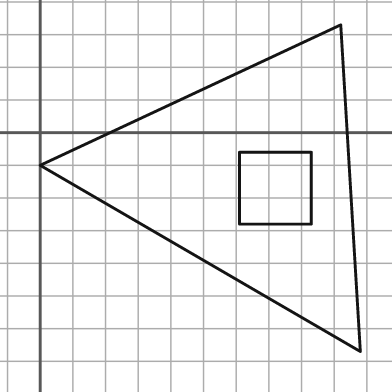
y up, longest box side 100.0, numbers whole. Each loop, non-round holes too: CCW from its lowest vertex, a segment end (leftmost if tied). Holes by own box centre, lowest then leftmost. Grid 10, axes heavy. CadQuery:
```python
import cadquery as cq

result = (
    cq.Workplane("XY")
    .moveTo(98.0, -67.0)
    .lineTo(92.0, 33.0)
    .lineTo(0.0, -10.0)
    .close()
    .moveTo(61.0, -28.0)
    .lineTo(83.0, -28.0)
    .lineTo(83.0, -6.0)
    .lineTo(61.0, -6.0)
    .close()
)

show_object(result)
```